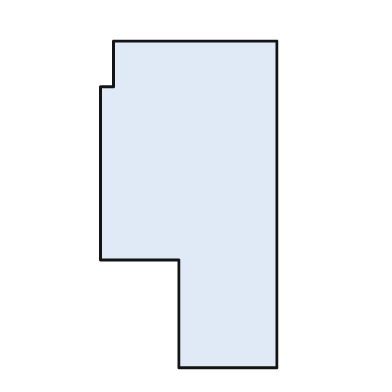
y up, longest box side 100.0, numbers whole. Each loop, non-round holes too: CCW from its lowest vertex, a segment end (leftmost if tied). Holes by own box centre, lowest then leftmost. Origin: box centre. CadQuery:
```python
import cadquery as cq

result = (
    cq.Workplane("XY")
    .moveTo(-3.0, -50.0)
    .lineTo(27.0, -50.0)
    .lineTo(27.0, 50.0)
    .lineTo(-23.0, 50.0)
    .lineTo(-23.0, 36.0)
    .lineTo(-27.0, 36.0)
    .lineTo(-27.0, -17.0)
    .lineTo(-3.0, -17.0)
    .close()
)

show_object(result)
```